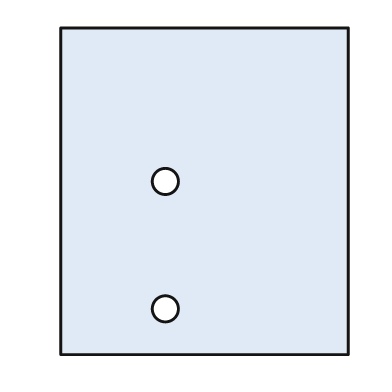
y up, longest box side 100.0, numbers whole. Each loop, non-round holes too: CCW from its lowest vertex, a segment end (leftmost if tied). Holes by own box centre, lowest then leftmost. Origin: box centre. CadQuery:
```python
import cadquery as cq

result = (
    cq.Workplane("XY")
    .moveTo(-44.0, -50.0)
    .lineTo(44.0, -50.0)
    .lineTo(44.0, 50.0)
    .lineTo(-44.0, 50.0)
    .close()
    .moveTo(-12.0, -36.0)
    .circle(4.0)
    .moveTo(-12.0, 3.0)
    .circle(4.0)
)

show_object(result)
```